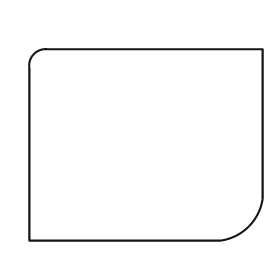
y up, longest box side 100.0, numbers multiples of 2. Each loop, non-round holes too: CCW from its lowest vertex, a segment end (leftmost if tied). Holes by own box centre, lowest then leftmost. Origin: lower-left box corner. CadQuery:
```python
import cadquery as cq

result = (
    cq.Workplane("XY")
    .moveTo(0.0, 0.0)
    .lineTo(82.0, 0.0)
    .threePointArc((94.0, 6.0), (100.0, 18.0))
    .lineTo(100.0, 82.0)
    .lineTo(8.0, 82.0)
    .threePointArc((2.0, 80.0), (0.0, 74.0))
    .close()
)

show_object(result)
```